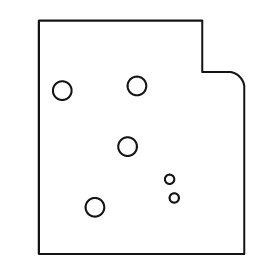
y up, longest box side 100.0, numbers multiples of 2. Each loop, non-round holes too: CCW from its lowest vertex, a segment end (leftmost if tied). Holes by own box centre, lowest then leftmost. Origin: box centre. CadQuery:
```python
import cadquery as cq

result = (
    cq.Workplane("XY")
    .moveTo(-44.0, -50.0)
    .lineTo(44.0, -50.0)
    .lineTo(44.0, 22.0)
    .threePointArc((42.0, 26.0), (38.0, 28.0))
    .lineTo(26.0, 28.0)
    .lineTo(26.0, 50.0)
    .lineTo(-44.0, 50.0)
    .close()
    .moveTo(-20.0, -30.0)
    .circle(4.0)
    .moveTo(14.0, -26.0)
    .circle(2.0)
    .moveTo(12.0, -18.0)
    .circle(2.0)
    .moveTo(-6.0, -4.0)
    .circle(4.0)
    .moveTo(-34.0, 20.0)
    .circle(4.0)
    .moveTo(-2.0, 22.0)
    .circle(4.0)
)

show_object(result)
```